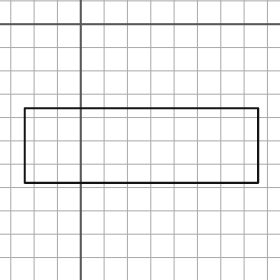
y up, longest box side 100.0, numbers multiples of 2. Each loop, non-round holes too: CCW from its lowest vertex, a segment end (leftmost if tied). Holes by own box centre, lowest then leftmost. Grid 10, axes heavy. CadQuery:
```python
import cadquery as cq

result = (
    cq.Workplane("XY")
    .moveTo(-24.0, -68.0)
    .lineTo(76.0, -68.0)
    .lineTo(76.0, -36.0)
    .lineTo(-24.0, -36.0)
    .close()
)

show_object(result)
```